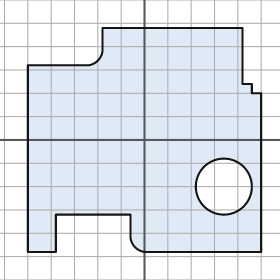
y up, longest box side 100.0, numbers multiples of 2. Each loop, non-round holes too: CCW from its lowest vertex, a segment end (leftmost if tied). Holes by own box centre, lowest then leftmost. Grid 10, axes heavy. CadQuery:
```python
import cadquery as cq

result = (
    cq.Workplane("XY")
    .moveTo(-50.0, -48.0)
    .lineTo(-38.0, -48.0)
    .lineTo(-38.0, -32.0)
    .lineTo(-6.0, -32.0)
    .lineTo(-6.0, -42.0)
    .threePointArc((-4.0, -46.0), (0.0, -48.0))
    .lineTo(50.0, -48.0)
    .lineTo(50.0, 20.0)
    .lineTo(46.0, 20.0)
    .lineTo(46.0, 24.0)
    .lineTo(42.0, 24.0)
    .lineTo(42.0, 48.0)
    .lineTo(-18.0, 48.0)
    .lineTo(-18.0, 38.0)
    .threePointArc((-20.0, 34.0), (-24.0, 32.0))
    .lineTo(-50.0, 32.0)
    .close()
    .moveTo(34.0, -20.0)
    .circle(12.0)
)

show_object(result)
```